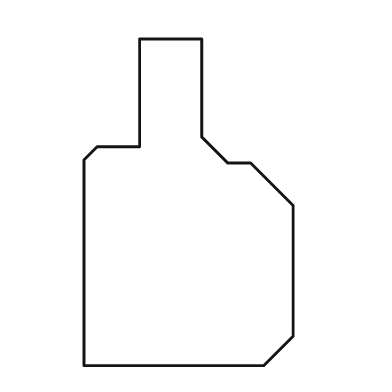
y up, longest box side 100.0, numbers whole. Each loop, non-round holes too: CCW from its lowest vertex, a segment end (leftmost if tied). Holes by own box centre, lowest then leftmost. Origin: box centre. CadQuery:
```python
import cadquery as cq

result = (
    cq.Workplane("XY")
    .moveTo(-32.0, -50.0)
    .lineTo(23.0, -50.0)
    .lineTo(32.0, -41.0)
    .lineTo(32.0, -1.0)
    .lineTo(19.0, 12.0)
    .lineTo(12.0, 12.0)
    .lineTo(4.0, 20.0)
    .lineTo(4.0, 50.0)
    .lineTo(-15.0, 50.0)
    .lineTo(-15.0, 17.0)
    .lineTo(-28.0, 17.0)
    .lineTo(-32.0, 13.0)
    .close()
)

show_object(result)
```